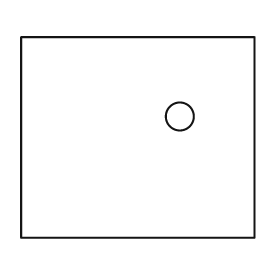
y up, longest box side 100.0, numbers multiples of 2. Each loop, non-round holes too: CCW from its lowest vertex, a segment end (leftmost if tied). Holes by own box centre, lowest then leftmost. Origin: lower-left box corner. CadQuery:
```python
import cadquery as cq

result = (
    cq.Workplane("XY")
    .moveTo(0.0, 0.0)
    .lineTo(100.0, 0.0)
    .lineTo(100.0, 86.0)
    .lineTo(0.0, 86.0)
    .close()
    .moveTo(68.0, 52.0)
    .circle(6.0)
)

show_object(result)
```